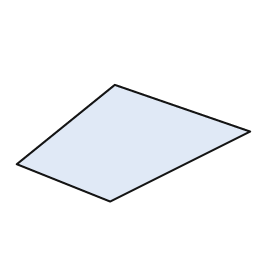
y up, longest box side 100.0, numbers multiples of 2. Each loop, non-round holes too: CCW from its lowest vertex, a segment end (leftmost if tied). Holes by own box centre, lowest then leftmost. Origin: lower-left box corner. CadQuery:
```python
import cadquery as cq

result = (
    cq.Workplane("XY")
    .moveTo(40.0, 0.0)
    .lineTo(100.0, 30.0)
    .lineTo(42.0, 50.0)
    .lineTo(0.0, 16.0)
    .close()
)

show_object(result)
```